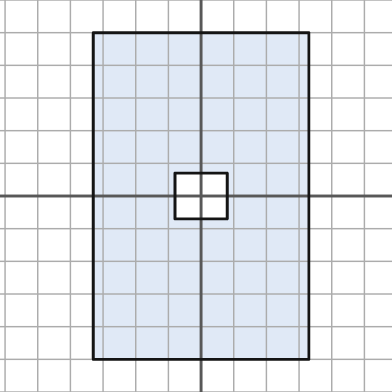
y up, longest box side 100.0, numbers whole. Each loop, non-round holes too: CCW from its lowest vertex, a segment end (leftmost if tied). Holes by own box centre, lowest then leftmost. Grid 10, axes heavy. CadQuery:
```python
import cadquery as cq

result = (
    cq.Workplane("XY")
    .moveTo(-33.0, -50.0)
    .lineTo(33.0, -50.0)
    .lineTo(33.0, 50.0)
    .lineTo(-33.0, 50.0)
    .close()
    .moveTo(-8.0, -7.0)
    .lineTo(8.0, -7.0)
    .lineTo(8.0, 7.0)
    .lineTo(-8.0, 7.0)
    .close()
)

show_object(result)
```